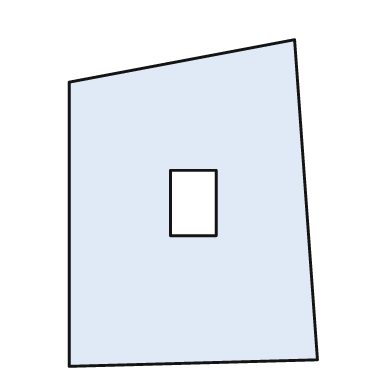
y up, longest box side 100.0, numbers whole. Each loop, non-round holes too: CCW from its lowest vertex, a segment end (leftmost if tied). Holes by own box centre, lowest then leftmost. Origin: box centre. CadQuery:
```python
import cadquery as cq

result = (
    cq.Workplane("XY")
    .moveTo(-38.0, -50.0)
    .lineTo(38.0, -48.0)
    .lineTo(31.0, 50.0)
    .lineTo(-38.0, 37.0)
    .close()
    .moveTo(-7.0, -10.0)
    .lineTo(7.0, -10.0)
    .lineTo(7.0, 10.0)
    .lineTo(-7.0, 10.0)
    .close()
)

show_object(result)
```